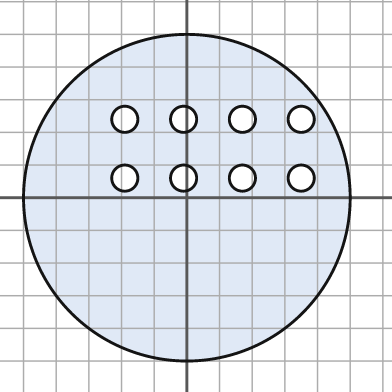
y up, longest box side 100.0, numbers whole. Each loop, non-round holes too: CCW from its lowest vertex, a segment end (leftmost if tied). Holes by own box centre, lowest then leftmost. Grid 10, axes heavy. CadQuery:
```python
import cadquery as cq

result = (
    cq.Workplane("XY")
    .moveTo(0.0, 0.0)
    .circle(50.0)
    .moveTo(-19.0, 6.0)
    .circle(4.0)
    .moveTo(-1.0, 6.0)
    .circle(4.0)
    .moveTo(17.0, 6.0)
    .circle(4.0)
    .moveTo(35.0, 6.0)
    .circle(4.0)
    .moveTo(-19.0, 24.0)
    .circle(4.0)
    .moveTo(-1.0, 24.0)
    .circle(4.0)
    .moveTo(17.0, 24.0)
    .circle(4.0)
    .moveTo(35.0, 24.0)
    .circle(4.0)
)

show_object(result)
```